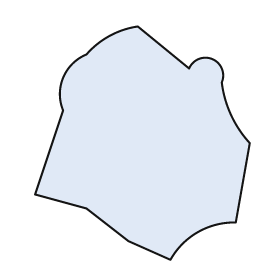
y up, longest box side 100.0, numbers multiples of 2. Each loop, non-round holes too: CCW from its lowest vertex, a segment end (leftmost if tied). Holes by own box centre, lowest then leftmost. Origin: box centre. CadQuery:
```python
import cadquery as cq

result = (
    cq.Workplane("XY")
    .moveTo(12.0, -50.0)
    .threePointArc((24.0, -38.0), (40.0, -34.0))
    .lineTo(46.0, 0.0)
    .threePointArc((38.0, 12.0), (34.0, 26.0))
    .threePointArc((30.0, 36.0), (20.0, 32.0))
    .lineTo(-2.0, 50.0)
    .threePointArc((-14.0, 46.0), (-24.0, 38.0))
    .threePointArc((-34.0, 28.0), (-34.0, 14.0))
    .lineTo(-46.0, -22.0)
    .lineTo(-24.0, -28.0)
    .lineTo(-6.0, -42.0)
    .close()
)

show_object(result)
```